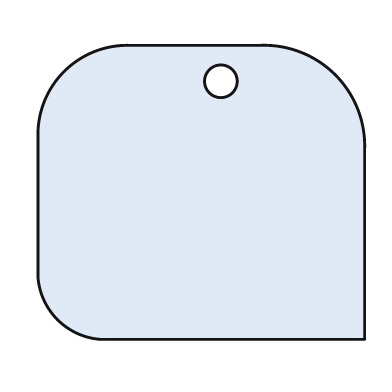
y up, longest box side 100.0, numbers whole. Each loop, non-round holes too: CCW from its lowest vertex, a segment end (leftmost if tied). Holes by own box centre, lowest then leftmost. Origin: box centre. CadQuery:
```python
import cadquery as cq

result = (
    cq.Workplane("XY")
    .moveTo(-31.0, -45.0)
    .lineTo(50.0, -45.0)
    .lineTo(50.0, 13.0)
    .threePointArc((41.0, 36.0), (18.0, 45.0))
    .lineTo(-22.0, 45.0)
    .threePointArc((-42.0, 37.0), (-50.0, 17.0))
    .lineTo(-50.0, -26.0)
    .threePointArc((-44.0, -39.0), (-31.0, -45.0))
    .close()
    .moveTo(6.0, 34.0)
    .circle(5.0)
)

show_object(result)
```